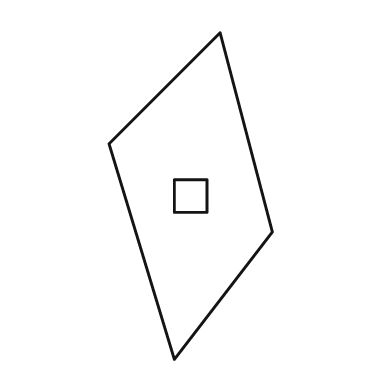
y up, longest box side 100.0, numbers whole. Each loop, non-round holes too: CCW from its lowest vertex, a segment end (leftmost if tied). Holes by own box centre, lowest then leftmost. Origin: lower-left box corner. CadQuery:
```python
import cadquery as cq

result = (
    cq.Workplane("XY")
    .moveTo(20.0, 0.0)
    .lineTo(50.0, 39.0)
    .lineTo(34.0, 100.0)
    .lineTo(0.0, 66.0)
    .close()
    .moveTo(20.0, 45.0)
    .lineTo(30.0, 45.0)
    .lineTo(30.0, 55.0)
    .lineTo(20.0, 55.0)
    .close()
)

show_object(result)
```